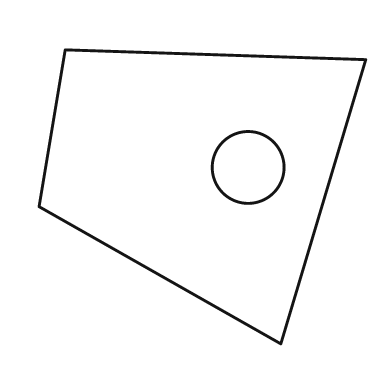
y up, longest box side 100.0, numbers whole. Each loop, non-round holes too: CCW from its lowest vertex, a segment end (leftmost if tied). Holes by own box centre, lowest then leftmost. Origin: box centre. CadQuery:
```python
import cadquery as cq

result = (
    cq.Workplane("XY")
    .moveTo(24.0, -45.0)
    .lineTo(50.0, 42.0)
    .lineTo(-42.0, 45.0)
    .lineTo(-50.0, -3.0)
    .close()
    .moveTo(14.0, 9.0)
    .circle(11.0)
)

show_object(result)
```